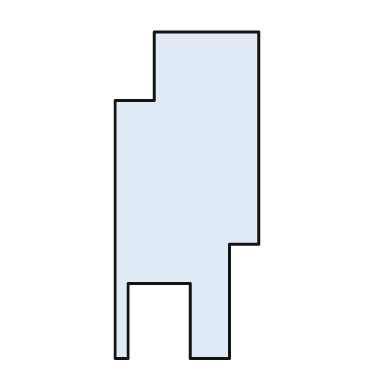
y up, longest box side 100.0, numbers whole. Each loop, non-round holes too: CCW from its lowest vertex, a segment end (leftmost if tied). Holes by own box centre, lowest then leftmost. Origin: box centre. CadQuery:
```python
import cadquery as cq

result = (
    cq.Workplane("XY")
    .moveTo(-22.0, -50.0)
    .lineTo(-18.0, -50.0)
    .lineTo(-18.0, -27.0)
    .lineTo(1.0, -27.0)
    .lineTo(1.0, -50.0)
    .lineTo(13.0, -50.0)
    .lineTo(13.0, -15.0)
    .lineTo(22.0, -15.0)
    .lineTo(22.0, 50.0)
    .lineTo(-10.0, 50.0)
    .lineTo(-10.0, 29.0)
    .lineTo(-22.0, 29.0)
    .close()
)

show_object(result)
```